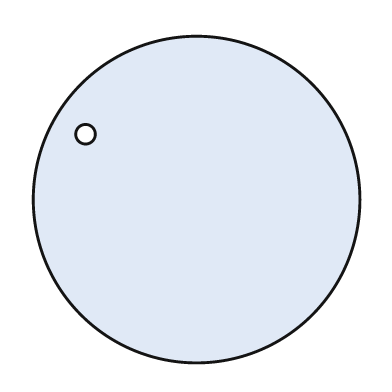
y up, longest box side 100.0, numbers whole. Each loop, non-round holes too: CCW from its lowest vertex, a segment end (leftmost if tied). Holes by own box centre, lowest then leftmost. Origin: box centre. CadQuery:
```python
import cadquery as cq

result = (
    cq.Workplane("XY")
    .moveTo(0.0, 0.0)
    .circle(50.0)
    .moveTo(-34.0, 20.0)
    .circle(3.0)
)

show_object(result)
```